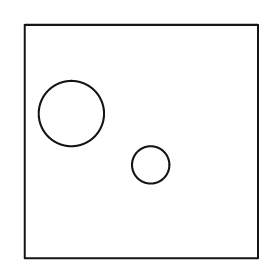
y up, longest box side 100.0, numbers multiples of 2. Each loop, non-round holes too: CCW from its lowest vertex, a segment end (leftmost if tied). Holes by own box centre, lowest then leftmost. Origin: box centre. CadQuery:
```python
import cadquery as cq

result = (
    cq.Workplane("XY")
    .moveTo(-50.0, -50.0)
    .lineTo(50.0, -50.0)
    .lineTo(50.0, 50.0)
    .lineTo(-50.0, 50.0)
    .close()
    .moveTo(4.0, -10.0)
    .circle(8.0)
    .moveTo(-30.0, 12.0)
    .circle(14.0)
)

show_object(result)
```